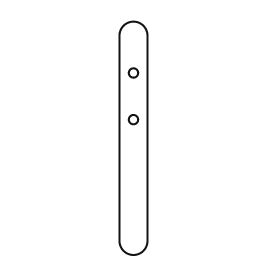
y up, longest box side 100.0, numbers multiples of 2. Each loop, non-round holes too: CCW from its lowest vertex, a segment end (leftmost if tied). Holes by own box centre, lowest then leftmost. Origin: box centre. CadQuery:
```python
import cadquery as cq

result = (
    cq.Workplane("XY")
    .moveTo(-6.0, -44.0)
    .threePointArc((0.0, -50.0), (6.0, -44.0))
    .lineTo(6.0, 44.0)
    .threePointArc((0.0, 50.0), (-6.0, 44.0))
    .close()
    .moveTo(0.0, 8.0)
    .circle(2.0)
    .moveTo(0.0, 28.0)
    .circle(2.0)
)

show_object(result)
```